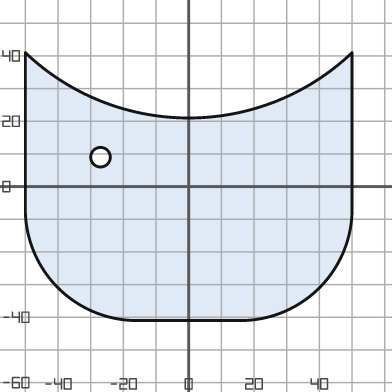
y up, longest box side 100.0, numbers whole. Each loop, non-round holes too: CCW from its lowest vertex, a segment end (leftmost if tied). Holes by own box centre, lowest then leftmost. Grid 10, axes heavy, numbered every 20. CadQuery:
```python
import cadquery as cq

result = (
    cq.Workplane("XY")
    .moveTo(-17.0, -41.0)
    .lineTo(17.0, -41.0)
    .threePointArc((40.0, -31.0), (50.0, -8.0))
    .lineTo(50.0, 41.0)
    .threePointArc((0.0, 21.0), (-50.0, 41.0))
    .lineTo(-50.0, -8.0)
    .threePointArc((-40.0, -31.0), (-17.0, -41.0))
    .close()
    .moveTo(-27.0, 9.0)
    .circle(3.0)
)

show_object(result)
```